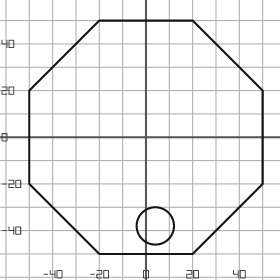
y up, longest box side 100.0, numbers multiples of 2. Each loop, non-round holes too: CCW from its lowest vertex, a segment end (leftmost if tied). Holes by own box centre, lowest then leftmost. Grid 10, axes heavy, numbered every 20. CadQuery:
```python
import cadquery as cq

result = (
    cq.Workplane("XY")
    .moveTo(-20.0, -50.0)
    .lineTo(20.0, -50.0)
    .lineTo(50.0, -20.0)
    .lineTo(50.0, 20.0)
    .lineTo(20.0, 50.0)
    .lineTo(-20.0, 50.0)
    .lineTo(-50.0, 20.0)
    .lineTo(-50.0, -20.0)
    .close()
    .moveTo(4.0, -38.0)
    .circle(8.0)
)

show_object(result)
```